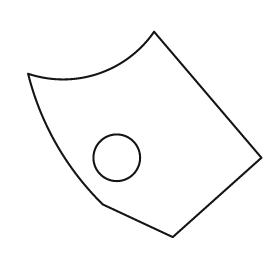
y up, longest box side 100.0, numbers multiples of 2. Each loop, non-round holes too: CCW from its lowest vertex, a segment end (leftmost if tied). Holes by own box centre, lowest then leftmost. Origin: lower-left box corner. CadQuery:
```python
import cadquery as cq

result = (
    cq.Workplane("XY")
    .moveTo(62.0, 0.0)
    .lineTo(100.0, 34.0)
    .lineTo(54.0, 88.0)
    .threePointArc((30.0, 70.0), (0.0, 70.0))
    .threePointArc((12.0, 40.0), (32.0, 14.0))
    .close()
    .moveTo(38.0, 34.0)
    .circle(10.0)
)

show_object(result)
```